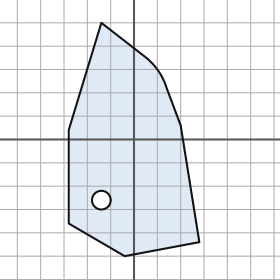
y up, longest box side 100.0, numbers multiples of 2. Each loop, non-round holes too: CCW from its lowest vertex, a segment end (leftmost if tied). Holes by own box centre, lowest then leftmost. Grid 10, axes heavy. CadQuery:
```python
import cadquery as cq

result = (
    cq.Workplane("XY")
    .moveTo(-4.0, -50.0)
    .lineTo(28.0, -44.0)
    .lineTo(20.0, 6.0)
    .lineTo(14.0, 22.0)
    .threePointArc((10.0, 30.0), (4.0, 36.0))
    .lineTo(-14.0, 50.0)
    .lineTo(-28.0, 4.0)
    .lineTo(-28.0, -36.0)
    .close()
    .moveTo(-14.0, -26.0)
    .circle(4.0)
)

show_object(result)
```